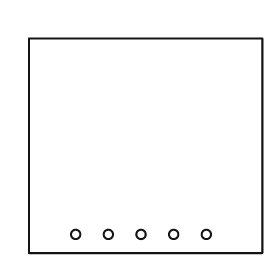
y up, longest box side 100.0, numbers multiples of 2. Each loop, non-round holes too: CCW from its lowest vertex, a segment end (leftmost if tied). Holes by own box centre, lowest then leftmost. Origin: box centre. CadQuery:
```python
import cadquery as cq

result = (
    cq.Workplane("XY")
    .moveTo(-50.0, -46.0)
    .lineTo(50.0, -46.0)
    .lineTo(50.0, 46.0)
    .lineTo(-50.0, 46.0)
    .close()
    .moveTo(-30.0, -38.0)
    .circle(2.0)
    .moveTo(-16.0, -38.0)
    .circle(2.0)
    .moveTo(-2.0, -38.0)
    .circle(2.0)
    .moveTo(12.0, -38.0)
    .circle(2.0)
    .moveTo(26.0, -38.0)
    .circle(2.0)
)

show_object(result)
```